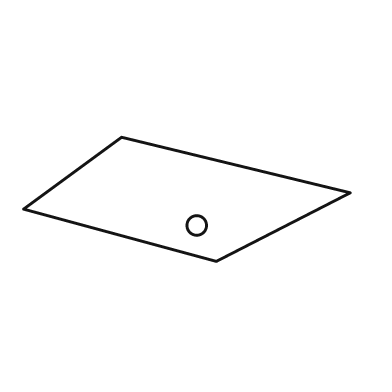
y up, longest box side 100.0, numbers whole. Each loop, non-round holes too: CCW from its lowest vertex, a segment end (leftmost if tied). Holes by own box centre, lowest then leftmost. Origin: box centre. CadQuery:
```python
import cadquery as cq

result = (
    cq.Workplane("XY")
    .moveTo(9.0, -19.0)
    .lineTo(50.0, 2.0)
    .lineTo(-20.0, 19.0)
    .lineTo(-50.0, -3.0)
    .close()
    .moveTo(3.0, -8.0)
    .circle(3.0)
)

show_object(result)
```